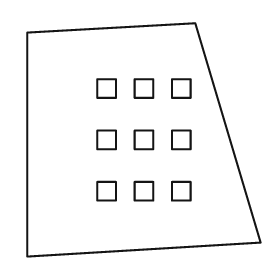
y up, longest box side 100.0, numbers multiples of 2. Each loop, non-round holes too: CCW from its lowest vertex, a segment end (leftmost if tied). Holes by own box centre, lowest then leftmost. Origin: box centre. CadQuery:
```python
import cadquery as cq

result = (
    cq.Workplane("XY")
    .moveTo(-50.0, -50.0)
    .lineTo(50.0, -44.0)
    .lineTo(22.0, 50.0)
    .lineTo(-50.0, 46.0)
    .close()
    .moveTo(-20.0, -26.0)
    .lineTo(-12.0, -26.0)
    .lineTo(-12.0, -18.0)
    .lineTo(-20.0, -18.0)
    .close()
    .moveTo(-4.0, -26.0)
    .lineTo(4.0, -26.0)
    .lineTo(4.0, -18.0)
    .lineTo(-4.0, -18.0)
    .close()
    .moveTo(12.0, -26.0)
    .lineTo(20.0, -26.0)
    .lineTo(20.0, -18.0)
    .lineTo(12.0, -18.0)
    .close()
    .moveTo(-20.0, -4.0)
    .lineTo(-12.0, -4.0)
    .lineTo(-12.0, 4.0)
    .lineTo(-20.0, 4.0)
    .close()
    .moveTo(-4.0, -4.0)
    .lineTo(4.0, -4.0)
    .lineTo(4.0, 4.0)
    .lineTo(-4.0, 4.0)
    .close()
    .moveTo(12.0, -4.0)
    .lineTo(20.0, -4.0)
    .lineTo(20.0, 4.0)
    .lineTo(12.0, 4.0)
    .close()
    .moveTo(-20.0, 18.0)
    .lineTo(-12.0, 18.0)
    .lineTo(-12.0, 26.0)
    .lineTo(-20.0, 26.0)
    .close()
    .moveTo(-4.0, 18.0)
    .lineTo(4.0, 18.0)
    .lineTo(4.0, 26.0)
    .lineTo(-4.0, 26.0)
    .close()
    .moveTo(12.0, 18.0)
    .lineTo(20.0, 18.0)
    .lineTo(20.0, 26.0)
    .lineTo(12.0, 26.0)
    .close()
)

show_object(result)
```